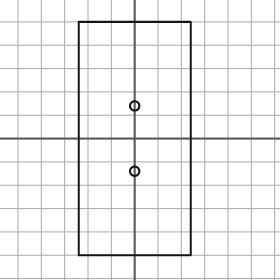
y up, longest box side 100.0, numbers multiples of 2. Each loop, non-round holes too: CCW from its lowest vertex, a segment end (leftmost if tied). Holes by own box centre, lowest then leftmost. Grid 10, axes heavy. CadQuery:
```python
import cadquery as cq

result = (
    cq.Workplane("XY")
    .moveTo(-24.0, -50.0)
    .lineTo(24.0, -50.0)
    .lineTo(24.0, 50.0)
    .lineTo(-24.0, 50.0)
    .close()
    .moveTo(0.0, -14.0)
    .circle(2.0)
    .moveTo(0.0, 14.0)
    .circle(2.0)
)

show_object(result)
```